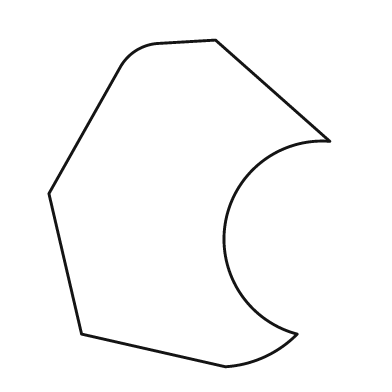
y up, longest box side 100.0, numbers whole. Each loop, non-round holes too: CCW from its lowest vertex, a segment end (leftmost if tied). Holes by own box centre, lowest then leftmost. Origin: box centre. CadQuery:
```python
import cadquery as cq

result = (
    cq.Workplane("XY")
    .moveTo(11.0, -50.0)
    .threePointArc((23.0, -47.0), (33.0, -40.0))
    .threePointArc((11.0, -6.0), (43.0, 19.0))
    .lineTo(8.0, 50.0)
    .lineTo(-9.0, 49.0)
    .threePointArc((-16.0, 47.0), (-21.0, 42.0))
    .lineTo(-43.0, 3.0)
    .lineTo(-33.0, -40.0)
    .close()
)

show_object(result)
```